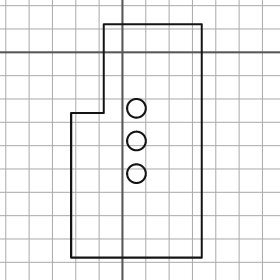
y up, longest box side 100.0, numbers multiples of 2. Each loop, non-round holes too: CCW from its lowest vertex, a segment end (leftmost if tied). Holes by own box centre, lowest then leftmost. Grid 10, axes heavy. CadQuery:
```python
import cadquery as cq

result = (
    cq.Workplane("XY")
    .moveTo(-22.0, -88.0)
    .lineTo(34.0, -88.0)
    .lineTo(34.0, 12.0)
    .lineTo(-8.0, 12.0)
    .lineTo(-8.0, -26.0)
    .lineTo(-22.0, -26.0)
    .close()
    .moveTo(6.0, -52.0)
    .circle(4.0)
    .moveTo(6.0, -38.0)
    .circle(4.0)
    .moveTo(6.0, -24.0)
    .circle(4.0)
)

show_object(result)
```